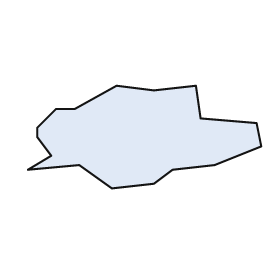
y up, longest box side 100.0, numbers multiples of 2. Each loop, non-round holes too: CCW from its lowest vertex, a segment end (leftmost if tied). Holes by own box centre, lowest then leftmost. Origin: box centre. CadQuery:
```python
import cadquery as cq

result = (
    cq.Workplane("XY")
    .moveTo(-14.0, -22.0)
    .lineTo(4.0, -20.0)
    .lineTo(12.0, -14.0)
    .lineTo(30.0, -12.0)
    .lineTo(50.0, -4.0)
    .lineTo(48.0, 6.0)
    .lineTo(24.0, 8.0)
    .lineTo(22.0, 22.0)
    .lineTo(4.0, 20.0)
    .lineTo(-12.0, 22.0)
    .lineTo(-30.0, 12.0)
    .lineTo(-38.0, 12.0)
    .lineTo(-46.0, 4.0)
    .lineTo(-46.0, 0.0)
    .lineTo(-40.0, -8.0)
    .lineTo(-50.0, -14.0)
    .lineTo(-28.0, -12.0)
    .close()
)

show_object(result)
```